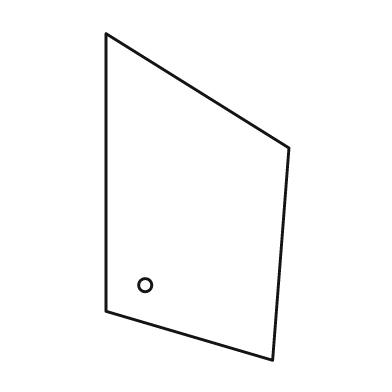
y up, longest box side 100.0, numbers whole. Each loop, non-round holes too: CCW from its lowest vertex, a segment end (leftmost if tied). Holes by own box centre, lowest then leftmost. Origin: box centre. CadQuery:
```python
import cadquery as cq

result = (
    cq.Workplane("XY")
    .moveTo(23.0, -50.0)
    .lineTo(28.0, 15.0)
    .lineTo(-28.0, 50.0)
    .lineTo(-28.0, -35.0)
    .close()
    .moveTo(-16.0, -27.0)
    .circle(2.0)
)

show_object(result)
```